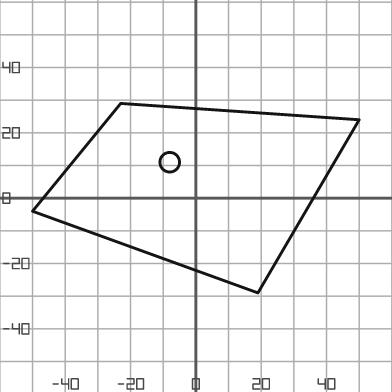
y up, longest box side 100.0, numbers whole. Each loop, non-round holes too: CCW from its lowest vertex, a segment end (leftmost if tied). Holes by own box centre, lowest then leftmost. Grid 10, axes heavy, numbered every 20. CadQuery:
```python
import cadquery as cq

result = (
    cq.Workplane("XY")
    .moveTo(19.0, -29.0)
    .lineTo(50.0, 24.0)
    .lineTo(-23.0, 29.0)
    .lineTo(-50.0, -4.0)
    .close()
    .moveTo(-8.0, 11.0)
    .circle(3.0)
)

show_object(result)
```